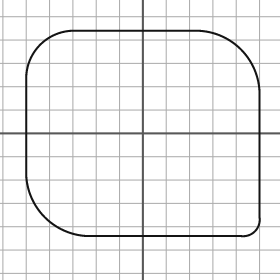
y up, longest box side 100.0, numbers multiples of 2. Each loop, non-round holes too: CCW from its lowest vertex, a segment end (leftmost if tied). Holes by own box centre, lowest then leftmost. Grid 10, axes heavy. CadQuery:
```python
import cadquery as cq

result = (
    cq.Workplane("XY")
    .moveTo(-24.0, -44.0)
    .lineTo(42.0, -44.0)
    .threePointArc((48.0, -42.0), (50.0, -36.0))
    .lineTo(50.0, 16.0)
    .threePointArc((42.0, 36.0), (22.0, 44.0))
    .lineTo(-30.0, 44.0)
    .threePointArc((-44.0, 38.0), (-50.0, 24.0))
    .lineTo(-50.0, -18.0)
    .threePointArc((-42.0, -36.0), (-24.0, -44.0))
    .close()
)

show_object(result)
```